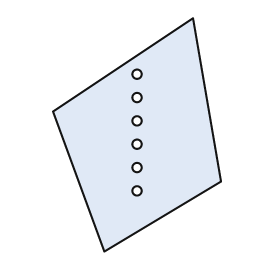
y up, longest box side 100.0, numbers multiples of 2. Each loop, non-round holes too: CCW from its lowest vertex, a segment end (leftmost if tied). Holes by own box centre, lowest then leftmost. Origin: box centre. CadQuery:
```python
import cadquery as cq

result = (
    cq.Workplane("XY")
    .moveTo(-14.0, -50.0)
    .lineTo(36.0, -20.0)
    .lineTo(24.0, 50.0)
    .lineTo(-36.0, 10.0)
    .close()
    .moveTo(0.0, -24.0)
    .circle(2.0)
    .moveTo(0.0, -14.0)
    .circle(2.0)
    .moveTo(0.0, -4.0)
    .circle(2.0)
    .moveTo(0.0, 6.0)
    .circle(2.0)
    .moveTo(0.0, 16.0)
    .circle(2.0)
    .moveTo(0.0, 26.0)
    .circle(2.0)
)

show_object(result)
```